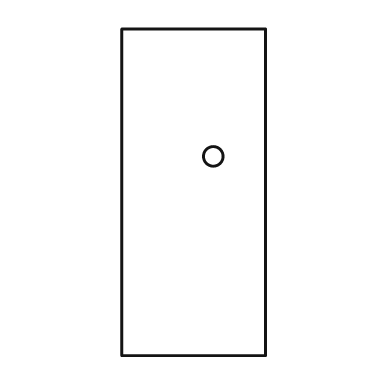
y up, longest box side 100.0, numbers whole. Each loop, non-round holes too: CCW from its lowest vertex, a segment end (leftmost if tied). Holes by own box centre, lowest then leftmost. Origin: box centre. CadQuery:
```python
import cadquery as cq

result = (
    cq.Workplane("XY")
    .moveTo(-22.0, -50.0)
    .lineTo(22.0, -50.0)
    .lineTo(22.0, 50.0)
    .lineTo(-22.0, 50.0)
    .close()
    .moveTo(6.0, 11.0)
    .circle(3.0)
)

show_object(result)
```